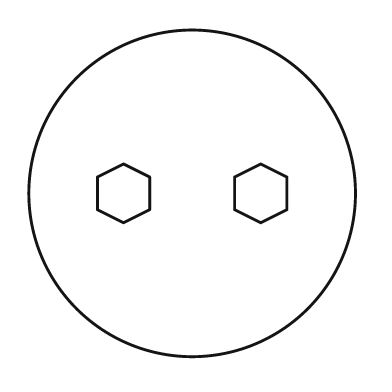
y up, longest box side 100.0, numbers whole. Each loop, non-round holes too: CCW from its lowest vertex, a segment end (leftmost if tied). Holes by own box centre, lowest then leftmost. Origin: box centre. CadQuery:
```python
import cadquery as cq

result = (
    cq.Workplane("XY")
    .moveTo(0.0, 0.0)
    .circle(50.0)
    .moveTo(-21.0, -9.0)
    .lineTo(-13.0, -5.0)
    .lineTo(-13.0, 5.0)
    .lineTo(-21.0, 9.0)
    .lineTo(-29.0, 5.0)
    .lineTo(-29.0, -5.0)
    .close()
    .moveTo(21.0, -9.0)
    .lineTo(29.0, -5.0)
    .lineTo(29.0, 5.0)
    .lineTo(21.0, 9.0)
    .lineTo(13.0, 5.0)
    .lineTo(13.0, -5.0)
    .close()
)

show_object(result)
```